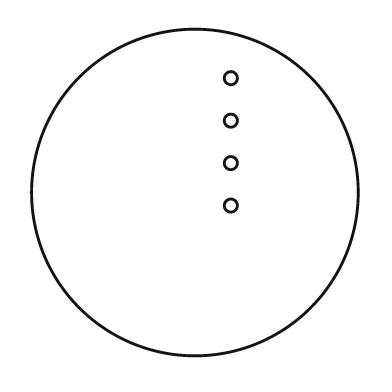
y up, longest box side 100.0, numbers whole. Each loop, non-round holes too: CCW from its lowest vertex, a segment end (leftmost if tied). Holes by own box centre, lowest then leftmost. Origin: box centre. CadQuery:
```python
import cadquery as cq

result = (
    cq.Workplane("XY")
    .moveTo(0.0, 0.0)
    .circle(50.0)
    .moveTo(11.0, -4.0)
    .circle(2.0)
    .moveTo(11.0, 9.0)
    .circle(2.0)
    .moveTo(11.0, 22.0)
    .circle(2.0)
    .moveTo(11.0, 35.0)
    .circle(2.0)
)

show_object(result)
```